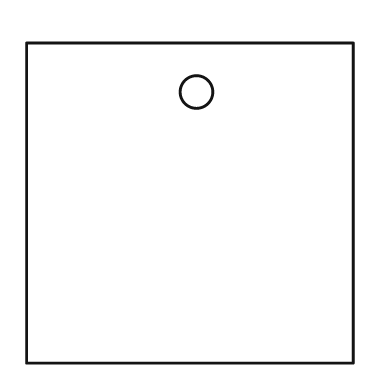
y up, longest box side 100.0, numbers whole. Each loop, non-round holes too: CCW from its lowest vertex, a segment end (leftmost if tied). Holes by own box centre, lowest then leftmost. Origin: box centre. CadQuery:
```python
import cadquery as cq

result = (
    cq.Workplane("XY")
    .moveTo(-50.0, -49.0)
    .lineTo(50.0, -49.0)
    .lineTo(50.0, 49.0)
    .lineTo(-50.0, 49.0)
    .close()
    .moveTo(2.0, 34.0)
    .circle(5.0)
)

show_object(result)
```